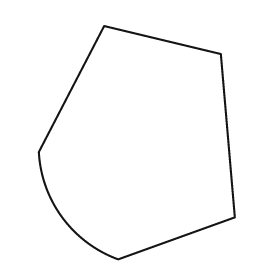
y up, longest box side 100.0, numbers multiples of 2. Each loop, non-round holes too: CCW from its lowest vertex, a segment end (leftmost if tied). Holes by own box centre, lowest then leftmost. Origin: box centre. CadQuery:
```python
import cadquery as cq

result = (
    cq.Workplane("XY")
    .moveTo(-8.0, -50.0)
    .lineTo(42.0, -32.0)
    .lineTo(36.0, 38.0)
    .lineTo(-14.0, 50.0)
    .lineTo(-42.0, -4.0)
    .threePointArc((-32.0, -32.0), (-8.0, -50.0))
    .close()
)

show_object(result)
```